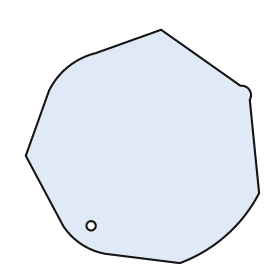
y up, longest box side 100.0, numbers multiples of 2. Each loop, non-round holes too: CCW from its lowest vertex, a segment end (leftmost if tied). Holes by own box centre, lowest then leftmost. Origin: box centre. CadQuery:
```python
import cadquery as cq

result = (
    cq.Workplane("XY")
    .moveTo(16.0, -50.0)
    .threePointArc((36.0, -38.0), (50.0, -20.0))
    .lineTo(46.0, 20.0)
    .threePointArc((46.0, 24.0), (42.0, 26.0))
    .lineTo(8.0, 50.0)
    .lineTo(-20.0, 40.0)
    .threePointArc((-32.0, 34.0), (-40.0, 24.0))
    .lineTo(-50.0, -4.0)
    .lineTo(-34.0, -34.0)
    .threePointArc((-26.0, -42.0), (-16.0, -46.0))
    .close()
    .moveTo(-22.0, -34.0)
    .circle(2.0)
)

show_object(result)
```